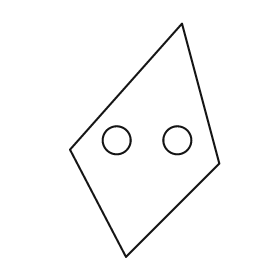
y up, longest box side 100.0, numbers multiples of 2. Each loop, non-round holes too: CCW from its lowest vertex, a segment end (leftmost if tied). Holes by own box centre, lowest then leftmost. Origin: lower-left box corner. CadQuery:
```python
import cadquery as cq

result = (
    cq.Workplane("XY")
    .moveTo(24.0, 0.0)
    .lineTo(64.0, 40.0)
    .lineTo(48.0, 100.0)
    .lineTo(0.0, 46.0)
    .close()
    .moveTo(20.0, 50.0)
    .circle(6.0)
    .moveTo(46.0, 50.0)
    .circle(6.0)
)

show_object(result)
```